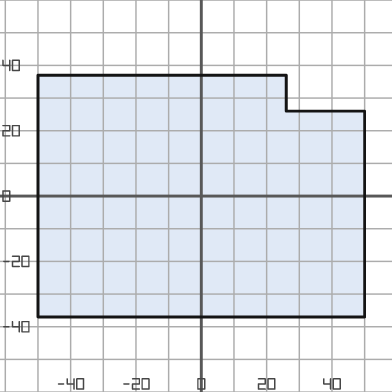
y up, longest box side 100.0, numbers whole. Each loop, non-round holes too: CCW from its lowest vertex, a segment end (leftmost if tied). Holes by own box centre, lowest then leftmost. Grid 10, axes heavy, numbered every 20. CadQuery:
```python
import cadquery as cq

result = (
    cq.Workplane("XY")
    .moveTo(-50.0, -37.0)
    .lineTo(50.0, -37.0)
    .lineTo(50.0, 26.0)
    .lineTo(26.0, 26.0)
    .lineTo(26.0, 37.0)
    .lineTo(-50.0, 37.0)
    .close()
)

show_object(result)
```